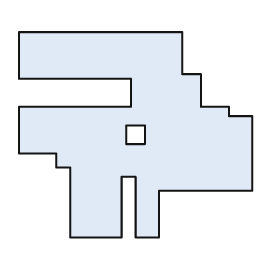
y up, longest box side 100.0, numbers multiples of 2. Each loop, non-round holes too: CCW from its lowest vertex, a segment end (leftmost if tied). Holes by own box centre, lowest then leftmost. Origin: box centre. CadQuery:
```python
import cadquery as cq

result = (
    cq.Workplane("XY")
    .moveTo(-28.0, -44.0)
    .lineTo(-6.0, -44.0)
    .lineTo(-6.0, -18.0)
    .lineTo(0.0, -18.0)
    .lineTo(0.0, -44.0)
    .lineTo(10.0, -44.0)
    .lineTo(10.0, -24.0)
    .lineTo(50.0, -24.0)
    .lineTo(50.0, 8.0)
    .lineTo(40.0, 8.0)
    .lineTo(40.0, 12.0)
    .lineTo(28.0, 12.0)
    .lineTo(28.0, 26.0)
    .lineTo(20.0, 26.0)
    .lineTo(20.0, 44.0)
    .lineTo(-50.0, 44.0)
    .lineTo(-50.0, 24.0)
    .lineTo(-2.0, 24.0)
    .lineTo(-2.0, 12.0)
    .lineTo(-50.0, 12.0)
    .lineTo(-50.0, -8.0)
    .lineTo(-34.0, -8.0)
    .lineTo(-34.0, -14.0)
    .lineTo(-28.0, -14.0)
    .close()
    .moveTo(-4.0, -4.0)
    .lineTo(4.0, -4.0)
    .lineTo(4.0, 4.0)
    .lineTo(-4.0, 4.0)
    .close()
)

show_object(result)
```